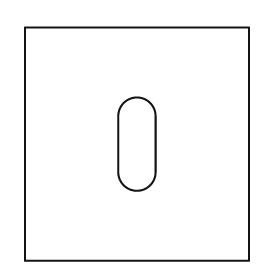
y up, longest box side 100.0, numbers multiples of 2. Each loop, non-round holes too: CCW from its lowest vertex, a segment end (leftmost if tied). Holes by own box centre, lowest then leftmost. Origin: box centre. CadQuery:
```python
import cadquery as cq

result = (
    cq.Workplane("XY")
    .moveTo(-48.0, -50.0)
    .lineTo(48.0, -50.0)
    .lineTo(48.0, 50.0)
    .lineTo(-48.0, 50.0)
    .close()
    .moveTo(-8.0, -12.0)
    .threePointArc((0.0, -20.0), (8.0, -12.0))
    .lineTo(8.0, 12.0)
    .threePointArc((0.0, 20.0), (-8.0, 12.0))
    .close()
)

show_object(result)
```